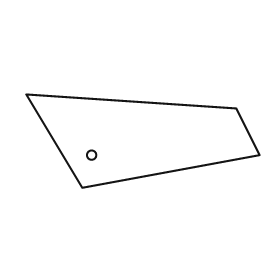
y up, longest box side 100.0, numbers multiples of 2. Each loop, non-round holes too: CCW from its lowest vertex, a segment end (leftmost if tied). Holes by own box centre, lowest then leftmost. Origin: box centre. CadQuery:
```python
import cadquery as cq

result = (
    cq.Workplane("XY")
    .moveTo(-26.0, -20.0)
    .lineTo(50.0, -6.0)
    .lineTo(40.0, 14.0)
    .lineTo(-50.0, 20.0)
    .close()
    .moveTo(-22.0, -6.0)
    .circle(2.0)
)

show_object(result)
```